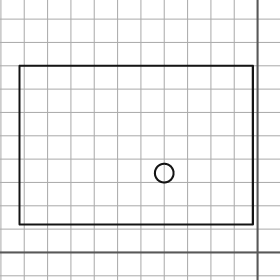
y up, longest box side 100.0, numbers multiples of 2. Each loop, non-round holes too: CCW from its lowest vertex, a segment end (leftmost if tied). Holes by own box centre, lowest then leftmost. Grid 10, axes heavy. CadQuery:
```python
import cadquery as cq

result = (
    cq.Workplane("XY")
    .moveTo(-102.0, 12.0)
    .lineTo(-2.0, 12.0)
    .lineTo(-2.0, 80.0)
    .lineTo(-102.0, 80.0)
    .close()
    .moveTo(-40.0, 34.0)
    .circle(4.0)
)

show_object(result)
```